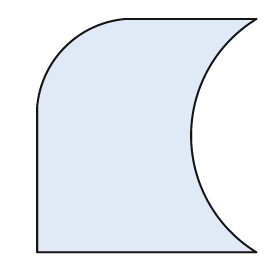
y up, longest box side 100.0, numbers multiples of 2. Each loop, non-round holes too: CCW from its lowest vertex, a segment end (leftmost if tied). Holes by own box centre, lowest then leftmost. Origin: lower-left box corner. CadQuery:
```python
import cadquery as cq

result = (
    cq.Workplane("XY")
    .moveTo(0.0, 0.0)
    .lineTo(94.0, 0.0)
    .threePointArc((66.0, 50.0), (94.0, 100.0))
    .lineTo(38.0, 100.0)
    .threePointArc((12.0, 88.0), (0.0, 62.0))
    .close()
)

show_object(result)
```